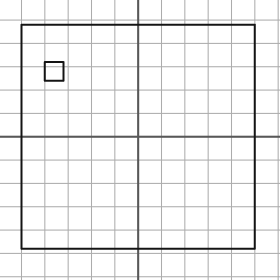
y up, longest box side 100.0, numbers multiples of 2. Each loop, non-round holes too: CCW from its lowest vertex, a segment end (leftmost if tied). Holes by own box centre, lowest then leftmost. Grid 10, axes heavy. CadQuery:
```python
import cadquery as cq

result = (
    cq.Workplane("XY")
    .moveTo(-50.0, -48.0)
    .lineTo(50.0, -48.0)
    .lineTo(50.0, 48.0)
    .lineTo(-50.0, 48.0)
    .close()
    .moveTo(-40.0, 24.0)
    .lineTo(-32.0, 24.0)
    .lineTo(-32.0, 32.0)
    .lineTo(-40.0, 32.0)
    .close()
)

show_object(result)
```